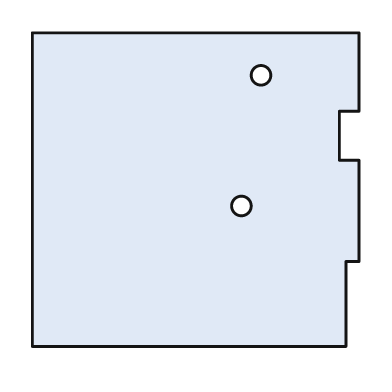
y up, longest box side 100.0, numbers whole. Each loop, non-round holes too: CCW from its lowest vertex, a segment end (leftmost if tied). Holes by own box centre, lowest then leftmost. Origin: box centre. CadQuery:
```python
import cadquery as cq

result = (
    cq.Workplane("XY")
    .moveTo(-50.0, -48.0)
    .lineTo(46.0, -48.0)
    .lineTo(46.0, -22.0)
    .lineTo(50.0, -22.0)
    .lineTo(50.0, 9.0)
    .lineTo(44.0, 9.0)
    .lineTo(44.0, 24.0)
    .lineTo(50.0, 24.0)
    .lineTo(50.0, 48.0)
    .lineTo(-50.0, 48.0)
    .close()
    .moveTo(14.0, -5.0)
    .circle(3.0)
    .moveTo(20.0, 35.0)
    .circle(3.0)
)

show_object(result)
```